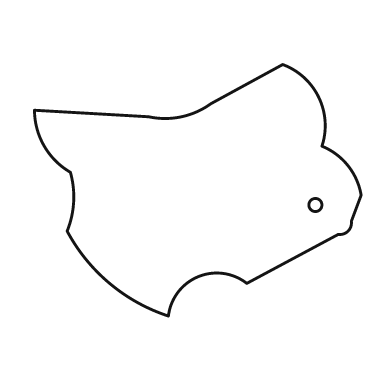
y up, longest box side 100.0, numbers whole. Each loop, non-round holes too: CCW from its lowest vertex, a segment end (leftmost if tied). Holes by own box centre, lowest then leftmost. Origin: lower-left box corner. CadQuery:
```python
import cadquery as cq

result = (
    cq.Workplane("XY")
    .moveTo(41.0, 0.0)
    .threePointArc((50.0, 12.0), (65.0, 10.0))
    .lineTo(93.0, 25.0)
    .threePointArc((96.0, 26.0), (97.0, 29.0))
    .lineTo(100.0, 37.0)
    .threePointArc((96.0, 46.0), (88.0, 52.0))
    .threePointArc((87.0, 67.0), (76.0, 77.0))
    .lineTo(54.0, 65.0)
    .threePointArc((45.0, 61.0), (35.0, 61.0))
    .lineTo(0.0, 63.0)
    .threePointArc((3.0, 52.0), (11.0, 44.0))
    .threePointArc((12.0, 35.0), (10.0, 26.0))
    .threePointArc((23.0, 10.0), (41.0, 0.0))
    .close()
    .moveTo(86.0, 34.0)
    .circle(2.0)
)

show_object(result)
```